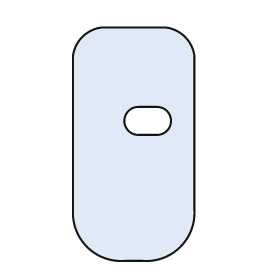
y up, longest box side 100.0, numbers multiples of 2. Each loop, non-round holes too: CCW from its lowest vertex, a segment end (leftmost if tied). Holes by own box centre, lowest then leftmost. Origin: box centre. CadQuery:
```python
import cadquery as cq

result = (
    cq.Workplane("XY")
    .moveTo(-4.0, -50.0)
    .lineTo(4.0, -50.0)
    .threePointArc((20.0, -44.0), (26.0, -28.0))
    .lineTo(26.0, 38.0)
    .threePointArc((22.0, 46.0), (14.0, 50.0))
    .lineTo(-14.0, 50.0)
    .threePointArc((-22.0, 46.0), (-26.0, 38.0))
    .lineTo(-26.0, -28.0)
    .threePointArc((-20.0, -44.0), (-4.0, -50.0))
    .close()
    .moveTo(2.0, 4.0)
    .lineTo(10.0, 4.0)
    .threePointArc((16.0, 10.0), (10.0, 16.0))
    .lineTo(2.0, 16.0)
    .threePointArc((-4.0, 10.0), (2.0, 4.0))
    .close()
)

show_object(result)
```